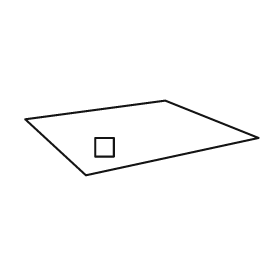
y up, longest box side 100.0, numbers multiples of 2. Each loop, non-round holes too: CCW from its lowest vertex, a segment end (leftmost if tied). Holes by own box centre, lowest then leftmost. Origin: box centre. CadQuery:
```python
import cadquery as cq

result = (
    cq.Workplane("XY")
    .moveTo(-24.0, -16.0)
    .lineTo(50.0, 0.0)
    .lineTo(10.0, 16.0)
    .lineTo(-50.0, 8.0)
    .close()
    .moveTo(-20.0, -8.0)
    .lineTo(-12.0, -8.0)
    .lineTo(-12.0, 0.0)
    .lineTo(-20.0, 0.0)
    .close()
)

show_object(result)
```